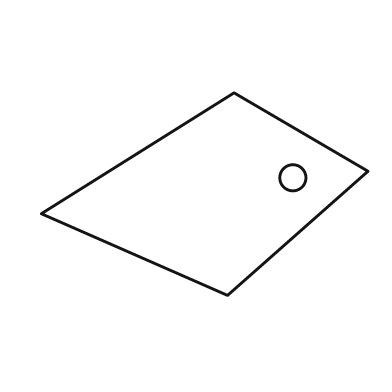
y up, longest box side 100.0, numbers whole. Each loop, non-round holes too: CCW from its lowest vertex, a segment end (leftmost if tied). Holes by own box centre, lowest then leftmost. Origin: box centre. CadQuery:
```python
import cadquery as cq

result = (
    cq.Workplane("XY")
    .moveTo(7.0, -31.0)
    .lineTo(50.0, 7.0)
    .lineTo(9.0, 31.0)
    .lineTo(-50.0, -6.0)
    .close()
    .moveTo(27.0, 5.0)
    .circle(4.0)
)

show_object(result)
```